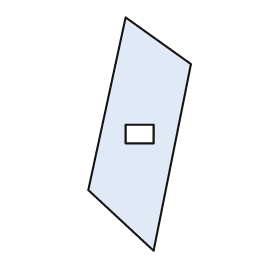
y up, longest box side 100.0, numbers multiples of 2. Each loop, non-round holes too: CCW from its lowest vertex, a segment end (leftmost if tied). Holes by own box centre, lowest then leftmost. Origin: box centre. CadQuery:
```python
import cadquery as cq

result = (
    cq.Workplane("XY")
    .moveTo(6.0, -50.0)
    .lineTo(22.0, 30.0)
    .lineTo(-6.0, 50.0)
    .lineTo(-22.0, -24.0)
    .close()
    .moveTo(-6.0, -4.0)
    .lineTo(6.0, -4.0)
    .lineTo(6.0, 4.0)
    .lineTo(-6.0, 4.0)
    .close()
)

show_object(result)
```